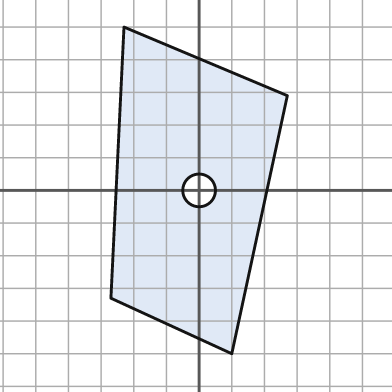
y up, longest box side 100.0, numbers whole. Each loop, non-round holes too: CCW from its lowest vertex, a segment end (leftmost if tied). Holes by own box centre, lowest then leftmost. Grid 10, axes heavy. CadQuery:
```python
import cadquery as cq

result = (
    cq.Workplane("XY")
    .moveTo(10.0, -50.0)
    .lineTo(27.0, 29.0)
    .lineTo(-23.0, 50.0)
    .lineTo(-27.0, -33.0)
    .close()
    .moveTo(0.0, 0.0)
    .circle(5.0)
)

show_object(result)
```